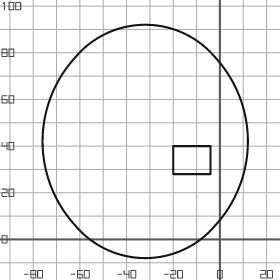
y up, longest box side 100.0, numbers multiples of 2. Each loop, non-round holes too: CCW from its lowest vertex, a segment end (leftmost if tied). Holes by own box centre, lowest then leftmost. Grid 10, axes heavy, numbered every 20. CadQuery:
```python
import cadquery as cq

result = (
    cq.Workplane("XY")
    .moveTo(-62.0, 6.0)
    .threePointArc((-32.0, -8.0), (-2.0, 6.0))
    .threePointArc((12.0, 42.0), (-2.0, 78.0))
    .threePointArc((-32.0, 92.0), (-62.0, 78.0))
    .threePointArc((-76.0, 42.0), (-62.0, 6.0))
    .close()
    .moveTo(-20.0, 28.0)
    .lineTo(-4.0, 28.0)
    .lineTo(-4.0, 40.0)
    .lineTo(-20.0, 40.0)
    .close()
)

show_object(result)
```